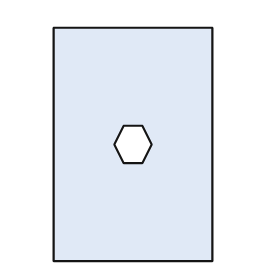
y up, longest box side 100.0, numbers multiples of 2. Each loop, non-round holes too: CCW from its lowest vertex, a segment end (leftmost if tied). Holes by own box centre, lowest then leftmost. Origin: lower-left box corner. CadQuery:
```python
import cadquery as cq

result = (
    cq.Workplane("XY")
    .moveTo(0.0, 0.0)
    .lineTo(68.0, 0.0)
    .lineTo(68.0, 100.0)
    .lineTo(0.0, 100.0)
    .close()
    .moveTo(30.0, 42.0)
    .lineTo(38.0, 42.0)
    .lineTo(42.0, 50.0)
    .lineTo(38.0, 58.0)
    .lineTo(30.0, 58.0)
    .lineTo(26.0, 50.0)
    .close()
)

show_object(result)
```